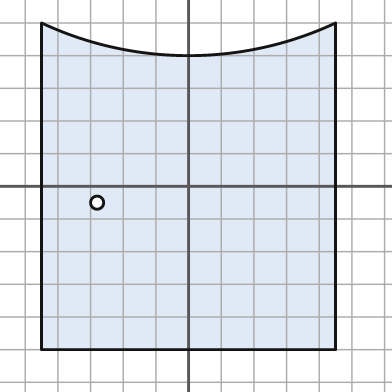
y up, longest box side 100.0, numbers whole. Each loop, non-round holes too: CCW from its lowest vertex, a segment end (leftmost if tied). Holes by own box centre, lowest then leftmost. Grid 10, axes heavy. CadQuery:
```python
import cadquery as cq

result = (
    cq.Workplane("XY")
    .moveTo(-45.0, -50.0)
    .lineTo(45.0, -50.0)
    .lineTo(45.0, 50.0)
    .threePointArc((0.0, 40.0), (-45.0, 50.0))
    .close()
    .moveTo(-28.0, -5.0)
    .circle(2.0)
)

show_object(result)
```